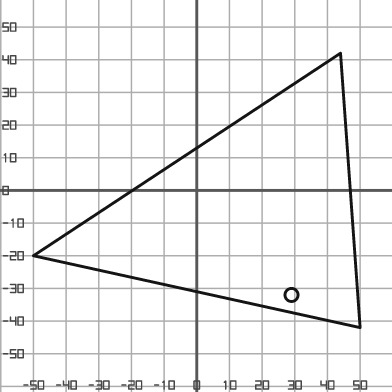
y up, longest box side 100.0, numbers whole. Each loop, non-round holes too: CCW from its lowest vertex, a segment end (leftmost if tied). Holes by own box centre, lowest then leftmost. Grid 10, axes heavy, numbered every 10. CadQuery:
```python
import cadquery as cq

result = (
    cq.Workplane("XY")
    .moveTo(50.0, -42.0)
    .lineTo(44.0, 42.0)
    .lineTo(-50.0, -20.0)
    .close()
    .moveTo(29.0, -32.0)
    .circle(2.0)
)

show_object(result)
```